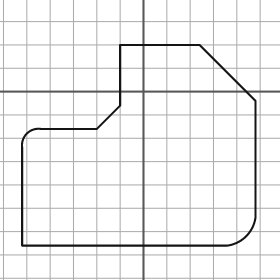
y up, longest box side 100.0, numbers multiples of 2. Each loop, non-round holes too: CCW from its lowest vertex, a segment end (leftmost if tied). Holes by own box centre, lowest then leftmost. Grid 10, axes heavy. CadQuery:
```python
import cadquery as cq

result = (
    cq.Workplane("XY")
    .moveTo(-52.0, -66.0)
    .lineTo(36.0, -66.0)
    .threePointArc((44.0, -62.0), (48.0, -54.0))
    .lineTo(48.0, -4.0)
    .lineTo(24.0, 20.0)
    .lineTo(-10.0, 20.0)
    .lineTo(-10.0, -6.0)
    .lineTo(-20.0, -16.0)
    .lineTo(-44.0, -16.0)
    .threePointArc((-50.0, -18.0), (-52.0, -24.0))
    .close()
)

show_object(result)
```